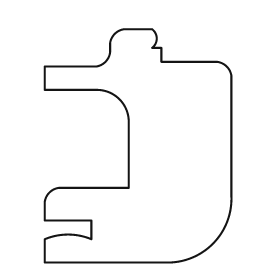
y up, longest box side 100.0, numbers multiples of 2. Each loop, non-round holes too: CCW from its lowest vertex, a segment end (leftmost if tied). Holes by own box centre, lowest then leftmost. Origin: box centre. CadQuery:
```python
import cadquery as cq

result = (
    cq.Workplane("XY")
    .moveTo(-40.0, -50.0)
    .lineTo(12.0, -50.0)
    .threePointArc((32.0, -42.0), (40.0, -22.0))
    .lineTo(40.0, 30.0)
    .threePointArc((38.0, 34.0), (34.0, 36.0))
    .lineTo(10.0, 36.0)
    .lineTo(10.0, 42.0)
    .lineTo(6.0, 42.0)
    .threePointArc((8.0, 46.0), (6.0, 50.0))
    .lineTo(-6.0, 50.0)
    .threePointArc((-10.0, 48.0), (-12.0, 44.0))
    .lineTo(-12.0, 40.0)
    .threePointArc((-14.0, 36.0), (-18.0, 34.0))
    .lineTo(-40.0, 34.0)
    .lineTo(-40.0, 24.0)
    .lineTo(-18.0, 24.0)
    .threePointArc((-8.0, 20.0), (-4.0, 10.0))
    .lineTo(-4.0, -18.0)
    .lineTo(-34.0, -18.0)
    .threePointArc((-38.0, -20.0), (-40.0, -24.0))
    .lineTo(-40.0, -32.0)
    .lineTo(-20.0, -32.0)
    .lineTo(-20.0, -40.0)
    .threePointArc((-30.0, -38.0), (-40.0, -40.0))
    .close()
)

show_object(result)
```